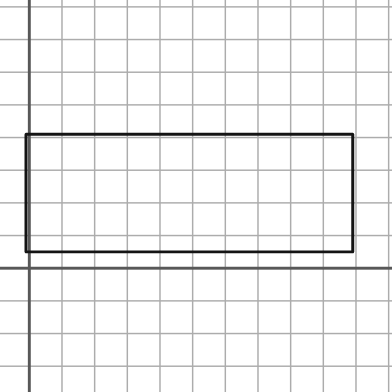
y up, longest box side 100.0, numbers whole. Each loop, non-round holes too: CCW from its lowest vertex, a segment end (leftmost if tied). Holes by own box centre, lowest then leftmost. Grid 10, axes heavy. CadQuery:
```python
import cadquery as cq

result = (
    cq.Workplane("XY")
    .moveTo(-1.0, 5.0)
    .lineTo(99.0, 5.0)
    .lineTo(99.0, 41.0)
    .lineTo(-1.0, 41.0)
    .close()
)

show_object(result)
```